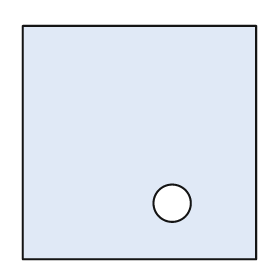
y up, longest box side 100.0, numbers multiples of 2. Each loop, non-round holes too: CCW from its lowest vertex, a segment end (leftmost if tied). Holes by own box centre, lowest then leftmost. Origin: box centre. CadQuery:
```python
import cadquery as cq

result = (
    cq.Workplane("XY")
    .moveTo(-50.0, -50.0)
    .lineTo(50.0, -50.0)
    .lineTo(50.0, 50.0)
    .lineTo(-50.0, 50.0)
    .close()
    .moveTo(14.0, -26.0)
    .circle(8.0)
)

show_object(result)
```